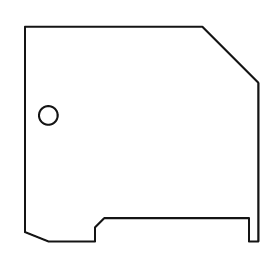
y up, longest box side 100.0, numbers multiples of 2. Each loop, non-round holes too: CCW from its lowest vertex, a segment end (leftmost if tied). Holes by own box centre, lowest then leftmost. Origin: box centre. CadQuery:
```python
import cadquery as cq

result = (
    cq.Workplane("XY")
    .moveTo(-40.0, -46.0)
    .lineTo(-20.0, -46.0)
    .lineTo(-20.0, -40.0)
    .lineTo(-16.0, -36.0)
    .lineTo(46.0, -36.0)
    .lineTo(46.0, -46.0)
    .lineTo(50.0, -46.0)
    .lineTo(50.0, 22.0)
    .lineTo(26.0, 46.0)
    .lineTo(-50.0, 46.0)
    .lineTo(-50.0, -42.0)
    .close()
    .moveTo(-40.0, 8.0)
    .circle(4.0)
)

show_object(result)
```